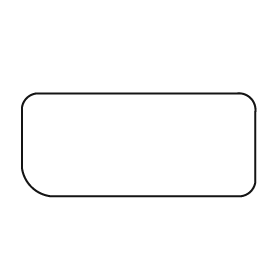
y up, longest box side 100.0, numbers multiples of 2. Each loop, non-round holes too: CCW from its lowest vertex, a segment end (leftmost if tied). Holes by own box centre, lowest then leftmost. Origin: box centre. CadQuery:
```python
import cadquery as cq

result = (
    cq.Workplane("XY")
    .moveTo(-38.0, -22.0)
    .lineTo(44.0, -22.0)
    .threePointArc((48.0, -20.0), (50.0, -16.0))
    .lineTo(50.0, 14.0)
    .threePointArc((48.0, 20.0), (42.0, 22.0))
    .lineTo(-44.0, 22.0)
    .threePointArc((-48.0, 20.0), (-50.0, 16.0))
    .lineTo(-50.0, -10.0)
    .threePointArc((-46.0, -18.0), (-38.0, -22.0))
    .close()
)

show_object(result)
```